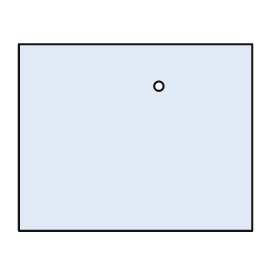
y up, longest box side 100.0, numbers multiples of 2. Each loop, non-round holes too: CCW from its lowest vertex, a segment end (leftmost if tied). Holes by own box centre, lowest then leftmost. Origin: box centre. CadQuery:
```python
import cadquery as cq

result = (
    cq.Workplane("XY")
    .moveTo(-50.0, -40.0)
    .lineTo(50.0, -40.0)
    .lineTo(50.0, 40.0)
    .lineTo(-50.0, 40.0)
    .close()
    .moveTo(10.0, 22.0)
    .circle(2.0)
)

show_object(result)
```